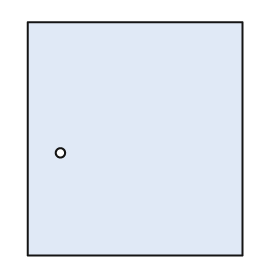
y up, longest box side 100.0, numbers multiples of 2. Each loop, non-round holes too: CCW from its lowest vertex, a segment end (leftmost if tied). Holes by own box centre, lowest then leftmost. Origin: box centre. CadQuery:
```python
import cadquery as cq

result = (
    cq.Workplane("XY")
    .moveTo(-46.0, -50.0)
    .lineTo(46.0, -50.0)
    .lineTo(46.0, 50.0)
    .lineTo(-46.0, 50.0)
    .close()
    .moveTo(-32.0, -6.0)
    .circle(2.0)
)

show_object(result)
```